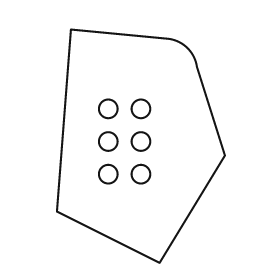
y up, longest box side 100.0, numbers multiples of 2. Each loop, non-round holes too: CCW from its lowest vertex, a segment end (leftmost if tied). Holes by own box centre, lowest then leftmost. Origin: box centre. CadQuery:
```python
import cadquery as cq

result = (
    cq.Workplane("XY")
    .moveTo(8.0, -50.0)
    .lineTo(36.0, -4.0)
    .lineTo(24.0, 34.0)
    .threePointArc((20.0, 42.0), (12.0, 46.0))
    .lineTo(-30.0, 50.0)
    .lineTo(-36.0, -28.0)
    .close()
    .moveTo(-14.0, -12.0)
    .circle(4.0)
    .moveTo(0.0, -12.0)
    .circle(4.0)
    .moveTo(-14.0, 2.0)
    .circle(4.0)
    .moveTo(0.0, 2.0)
    .circle(4.0)
    .moveTo(-14.0, 16.0)
    .circle(4.0)
    .moveTo(0.0, 16.0)
    .circle(4.0)
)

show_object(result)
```